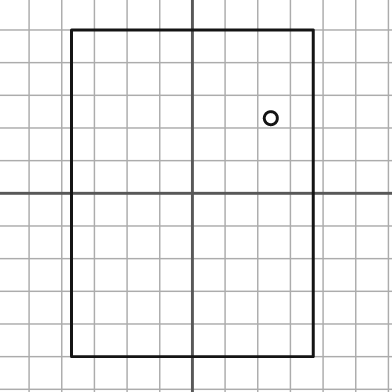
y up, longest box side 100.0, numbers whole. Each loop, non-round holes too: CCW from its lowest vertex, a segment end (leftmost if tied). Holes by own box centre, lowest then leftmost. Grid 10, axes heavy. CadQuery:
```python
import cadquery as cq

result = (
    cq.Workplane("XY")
    .moveTo(-37.0, -50.0)
    .lineTo(37.0, -50.0)
    .lineTo(37.0, 50.0)
    .lineTo(-37.0, 50.0)
    .close()
    .moveTo(24.0, 23.0)
    .circle(2.0)
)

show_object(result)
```